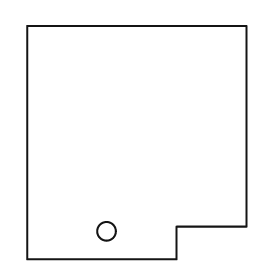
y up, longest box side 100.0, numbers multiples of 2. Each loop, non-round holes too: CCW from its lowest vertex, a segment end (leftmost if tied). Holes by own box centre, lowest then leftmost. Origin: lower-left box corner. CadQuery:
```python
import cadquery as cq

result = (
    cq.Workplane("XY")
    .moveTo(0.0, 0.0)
    .lineTo(64.0, 0.0)
    .lineTo(64.0, 14.0)
    .lineTo(94.0, 14.0)
    .lineTo(94.0, 100.0)
    .lineTo(0.0, 100.0)
    .close()
    .moveTo(34.0, 12.0)
    .circle(4.0)
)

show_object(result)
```